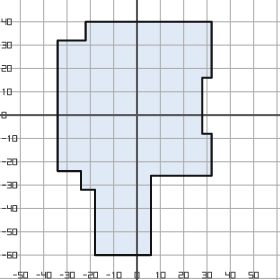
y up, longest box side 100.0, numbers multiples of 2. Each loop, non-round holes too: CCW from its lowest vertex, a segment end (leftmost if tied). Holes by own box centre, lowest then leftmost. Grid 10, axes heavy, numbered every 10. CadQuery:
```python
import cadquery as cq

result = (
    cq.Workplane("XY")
    .moveTo(-18.0, -60.0)
    .lineTo(6.0, -60.0)
    .lineTo(6.0, -26.0)
    .lineTo(32.0, -26.0)
    .lineTo(32.0, -8.0)
    .lineTo(28.0, -8.0)
    .lineTo(28.0, 16.0)
    .lineTo(32.0, 16.0)
    .lineTo(32.0, 40.0)
    .lineTo(-22.0, 40.0)
    .lineTo(-22.0, 32.0)
    .lineTo(-34.0, 32.0)
    .lineTo(-34.0, -24.0)
    .lineTo(-24.0, -24.0)
    .lineTo(-24.0, -32.0)
    .lineTo(-18.0, -32.0)
    .close()
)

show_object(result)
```